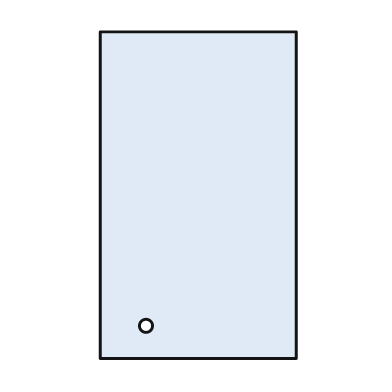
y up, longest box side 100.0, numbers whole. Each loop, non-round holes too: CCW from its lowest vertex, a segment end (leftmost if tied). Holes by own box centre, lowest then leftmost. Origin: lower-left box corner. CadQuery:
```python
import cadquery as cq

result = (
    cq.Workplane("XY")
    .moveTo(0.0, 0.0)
    .lineTo(60.0, 0.0)
    .lineTo(60.0, 100.0)
    .lineTo(0.0, 100.0)
    .close()
    .moveTo(14.0, 10.0)
    .circle(2.0)
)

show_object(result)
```